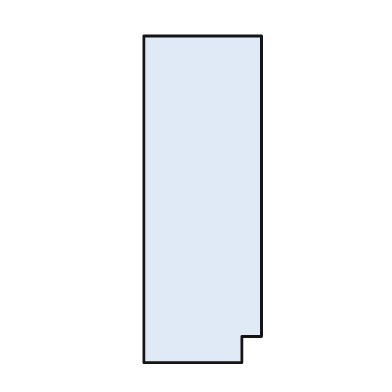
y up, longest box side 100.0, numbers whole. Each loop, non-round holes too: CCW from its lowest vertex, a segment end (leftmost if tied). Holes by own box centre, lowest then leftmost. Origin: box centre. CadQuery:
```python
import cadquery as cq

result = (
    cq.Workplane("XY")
    .moveTo(-18.0, -50.0)
    .lineTo(12.0, -50.0)
    .lineTo(12.0, -42.0)
    .lineTo(18.0, -42.0)
    .lineTo(18.0, 50.0)
    .lineTo(-18.0, 50.0)
    .close()
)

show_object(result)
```